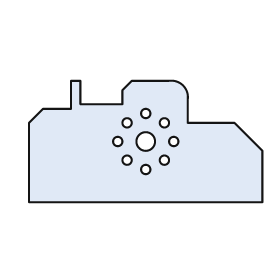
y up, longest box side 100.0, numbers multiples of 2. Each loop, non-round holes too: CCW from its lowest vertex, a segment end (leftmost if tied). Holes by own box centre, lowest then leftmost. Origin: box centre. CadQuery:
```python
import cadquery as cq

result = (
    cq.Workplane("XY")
    .moveTo(-50.0, -26.0)
    .lineTo(50.0, -26.0)
    .lineTo(50.0, -4.0)
    .lineTo(38.0, 8.0)
    .lineTo(18.0, 8.0)
    .lineTo(18.0, 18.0)
    .threePointArc((16.0, 24.0), (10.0, 26.0))
    .lineTo(-6.0, 26.0)
    .lineTo(-10.0, 22.0)
    .lineTo(-10.0, 16.0)
    .lineTo(-28.0, 16.0)
    .lineTo(-28.0, 26.0)
    .lineTo(-32.0, 26.0)
    .lineTo(-32.0, 14.0)
    .lineTo(-44.0, 14.0)
    .lineTo(-50.0, 8.0)
    .close()
    .moveTo(0.0, -12.0)
    .circle(2.0)
    .moveTo(-8.0, -8.0)
    .circle(2.0)
    .moveTo(8.0, -8.0)
    .circle(2.0)
    .moveTo(-12.0, 0.0)
    .circle(2.0)
    .moveTo(0.0, 0.0)
    .circle(4.0)
    .moveTo(12.0, 0.0)
    .circle(2.0)
    .moveTo(-8.0, 8.0)
    .circle(2.0)
    .moveTo(8.0, 8.0)
    .circle(2.0)
    .moveTo(0.0, 12.0)
    .circle(2.0)
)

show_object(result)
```